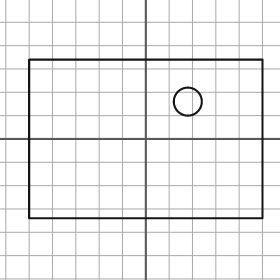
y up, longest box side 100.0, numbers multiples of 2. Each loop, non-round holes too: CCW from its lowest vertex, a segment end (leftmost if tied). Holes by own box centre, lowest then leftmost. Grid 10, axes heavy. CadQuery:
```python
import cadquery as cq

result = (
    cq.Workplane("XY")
    .moveTo(-50.0, -34.0)
    .lineTo(50.0, -34.0)
    .lineTo(50.0, 34.0)
    .lineTo(-50.0, 34.0)
    .close()
    .moveTo(18.0, 16.0)
    .circle(6.0)
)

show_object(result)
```